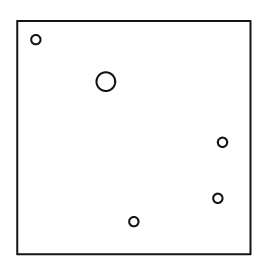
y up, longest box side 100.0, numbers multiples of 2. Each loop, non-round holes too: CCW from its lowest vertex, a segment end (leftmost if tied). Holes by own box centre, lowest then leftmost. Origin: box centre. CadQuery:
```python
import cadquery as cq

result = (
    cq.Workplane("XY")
    .moveTo(-50.0, -50.0)
    .lineTo(50.0, -50.0)
    .lineTo(50.0, 50.0)
    .lineTo(-50.0, 50.0)
    .close()
    .moveTo(0.0, -36.0)
    .circle(2.0)
    .moveTo(36.0, -26.0)
    .circle(2.0)
    .moveTo(38.0, -2.0)
    .circle(2.0)
    .moveTo(-12.0, 24.0)
    .circle(4.0)
    .moveTo(-42.0, 42.0)
    .circle(2.0)
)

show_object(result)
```